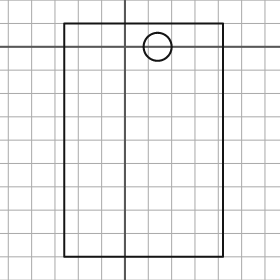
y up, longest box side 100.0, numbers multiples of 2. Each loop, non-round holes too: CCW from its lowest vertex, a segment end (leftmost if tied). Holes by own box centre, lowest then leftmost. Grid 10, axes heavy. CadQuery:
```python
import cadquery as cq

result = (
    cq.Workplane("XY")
    .moveTo(-26.0, -90.0)
    .lineTo(42.0, -90.0)
    .lineTo(42.0, 10.0)
    .lineTo(-26.0, 10.0)
    .close()
    .moveTo(14.0, 0.0)
    .circle(6.0)
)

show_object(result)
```